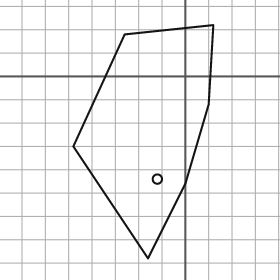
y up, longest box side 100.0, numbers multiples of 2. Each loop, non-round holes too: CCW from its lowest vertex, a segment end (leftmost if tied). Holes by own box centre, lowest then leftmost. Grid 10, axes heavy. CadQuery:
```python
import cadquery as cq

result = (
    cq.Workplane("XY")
    .moveTo(-16.0, -78.0)
    .lineTo(0.0, -46.0)
    .lineTo(10.0, -12.0)
    .lineTo(12.0, 22.0)
    .lineTo(-26.0, 18.0)
    .lineTo(-48.0, -30.0)
    .close()
    .moveTo(-12.0, -44.0)
    .circle(2.0)
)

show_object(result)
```